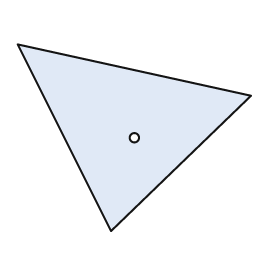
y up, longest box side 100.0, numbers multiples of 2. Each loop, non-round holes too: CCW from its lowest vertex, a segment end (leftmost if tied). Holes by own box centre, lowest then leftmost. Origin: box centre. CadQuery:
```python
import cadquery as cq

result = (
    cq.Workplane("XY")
    .moveTo(-10.0, -40.0)
    .lineTo(50.0, 18.0)
    .lineTo(-50.0, 40.0)
    .close()
    .moveTo(0.0, 0.0)
    .circle(2.0)
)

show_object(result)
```